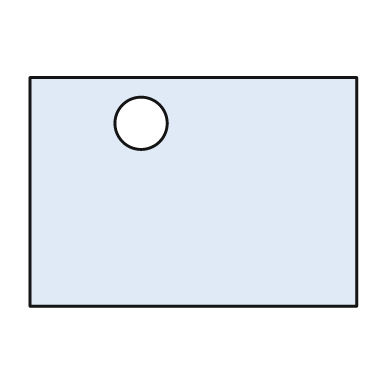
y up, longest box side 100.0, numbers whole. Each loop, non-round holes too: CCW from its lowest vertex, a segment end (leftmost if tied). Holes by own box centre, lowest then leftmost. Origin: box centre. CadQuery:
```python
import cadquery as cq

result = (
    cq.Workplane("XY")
    .moveTo(-50.0, -35.0)
    .lineTo(50.0, -35.0)
    .lineTo(50.0, 35.0)
    .lineTo(-50.0, 35.0)
    .close()
    .moveTo(-16.0, 21.0)
    .circle(8.0)
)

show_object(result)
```